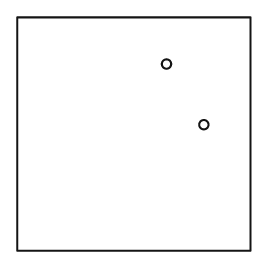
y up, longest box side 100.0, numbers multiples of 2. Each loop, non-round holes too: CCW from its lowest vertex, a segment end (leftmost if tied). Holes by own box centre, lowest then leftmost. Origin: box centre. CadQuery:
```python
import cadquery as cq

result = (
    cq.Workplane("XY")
    .moveTo(-50.0, -50.0)
    .lineTo(50.0, -50.0)
    .lineTo(50.0, 50.0)
    .lineTo(-50.0, 50.0)
    .close()
    .moveTo(30.0, 4.0)
    .circle(2.0)
    .moveTo(14.0, 30.0)
    .circle(2.0)
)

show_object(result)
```